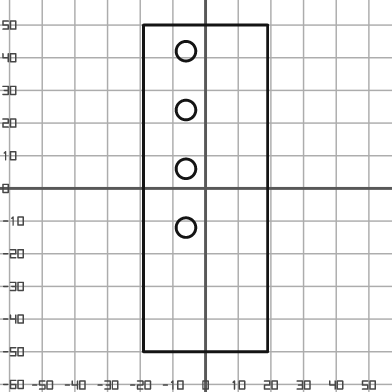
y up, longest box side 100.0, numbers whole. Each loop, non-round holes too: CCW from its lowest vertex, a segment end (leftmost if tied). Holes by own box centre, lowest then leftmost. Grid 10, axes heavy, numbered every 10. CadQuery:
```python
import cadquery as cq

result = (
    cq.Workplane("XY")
    .moveTo(-19.0, -50.0)
    .lineTo(19.0, -50.0)
    .lineTo(19.0, 50.0)
    .lineTo(-19.0, 50.0)
    .close()
    .moveTo(-6.0, -12.0)
    .circle(3.0)
    .moveTo(-6.0, 6.0)
    .circle(3.0)
    .moveTo(-6.0, 24.0)
    .circle(3.0)
    .moveTo(-6.0, 42.0)
    .circle(3.0)
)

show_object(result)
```